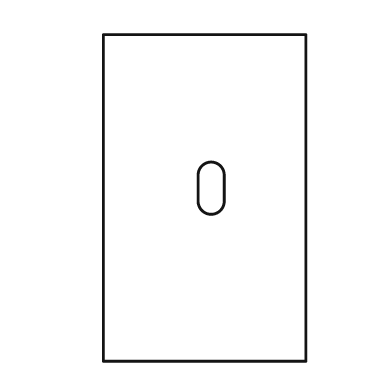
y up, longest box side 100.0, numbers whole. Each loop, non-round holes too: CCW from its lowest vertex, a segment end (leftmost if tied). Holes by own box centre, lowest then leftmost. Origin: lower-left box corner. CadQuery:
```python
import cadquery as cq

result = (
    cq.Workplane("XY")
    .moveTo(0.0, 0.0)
    .lineTo(62.0, 0.0)
    .lineTo(62.0, 100.0)
    .lineTo(0.0, 100.0)
    .close()
    .moveTo(29.0, 49.0)
    .threePointArc((33.0, 45.0), (37.0, 49.0))
    .lineTo(37.0, 57.0)
    .threePointArc((33.0, 61.0), (29.0, 57.0))
    .close()
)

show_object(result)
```